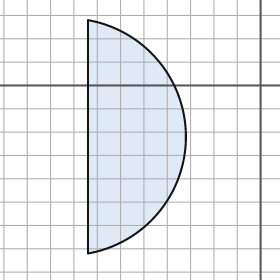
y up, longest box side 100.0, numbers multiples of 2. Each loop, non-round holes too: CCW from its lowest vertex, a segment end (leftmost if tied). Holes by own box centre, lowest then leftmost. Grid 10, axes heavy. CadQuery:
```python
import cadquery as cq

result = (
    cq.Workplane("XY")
    .moveTo(-74.0, -72.0)
    .threePointArc((-32.0, -22.0), (-74.0, 28.0))
    .close()
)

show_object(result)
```